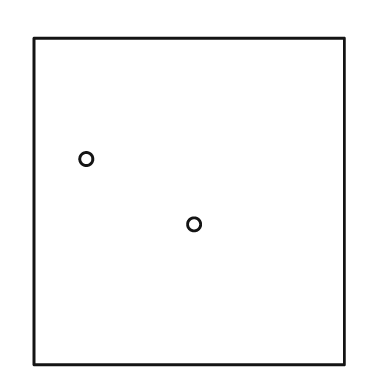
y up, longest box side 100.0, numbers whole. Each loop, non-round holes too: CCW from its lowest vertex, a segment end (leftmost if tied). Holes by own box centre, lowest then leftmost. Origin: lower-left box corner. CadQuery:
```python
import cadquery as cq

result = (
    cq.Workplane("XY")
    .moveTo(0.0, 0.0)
    .lineTo(95.0, 0.0)
    .lineTo(95.0, 100.0)
    .lineTo(0.0, 100.0)
    .close()
    .moveTo(49.0, 43.0)
    .circle(2.0)
    .moveTo(16.0, 63.0)
    .circle(2.0)
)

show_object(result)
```